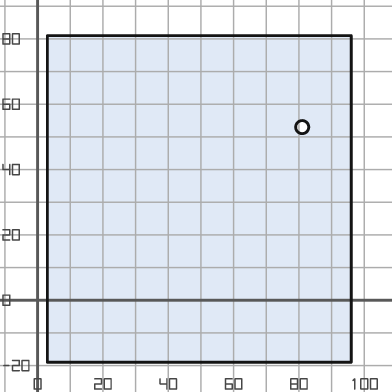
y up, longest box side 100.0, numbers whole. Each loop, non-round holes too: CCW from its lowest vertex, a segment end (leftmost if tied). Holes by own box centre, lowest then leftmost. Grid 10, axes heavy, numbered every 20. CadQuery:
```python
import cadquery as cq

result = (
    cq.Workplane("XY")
    .moveTo(3.0, -19.0)
    .lineTo(96.0, -19.0)
    .lineTo(96.0, 81.0)
    .lineTo(3.0, 81.0)
    .close()
    .moveTo(81.0, 53.0)
    .circle(2.0)
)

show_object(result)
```